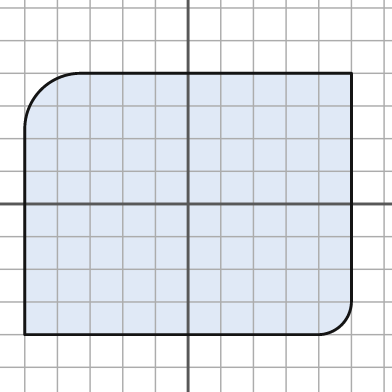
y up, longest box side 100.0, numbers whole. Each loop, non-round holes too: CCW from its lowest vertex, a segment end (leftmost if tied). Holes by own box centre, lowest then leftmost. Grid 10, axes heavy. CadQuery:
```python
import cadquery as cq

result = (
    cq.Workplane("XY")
    .moveTo(-50.0, -40.0)
    .lineTo(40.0, -40.0)
    .threePointArc((47.0, -37.0), (50.0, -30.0))
    .lineTo(50.0, 40.0)
    .lineTo(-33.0, 40.0)
    .threePointArc((-45.0, 35.0), (-50.0, 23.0))
    .close()
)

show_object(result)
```